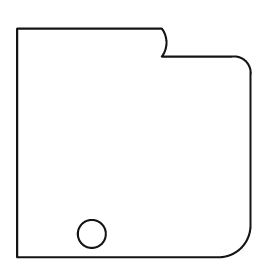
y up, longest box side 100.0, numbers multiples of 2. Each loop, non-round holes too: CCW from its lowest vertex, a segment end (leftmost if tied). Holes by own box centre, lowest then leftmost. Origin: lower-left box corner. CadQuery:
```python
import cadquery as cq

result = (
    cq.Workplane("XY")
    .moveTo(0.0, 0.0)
    .lineTo(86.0, 0.0)
    .threePointArc((96.0, 4.0), (100.0, 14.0))
    .lineTo(100.0, 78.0)
    .threePointArc((98.0, 84.0), (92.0, 86.0))
    .lineTo(62.0, 86.0)
    .threePointArc((64.0, 92.0), (62.0, 98.0))
    .lineTo(0.0, 98.0)
    .close()
    .moveTo(32.0, 10.0)
    .circle(6.0)
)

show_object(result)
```